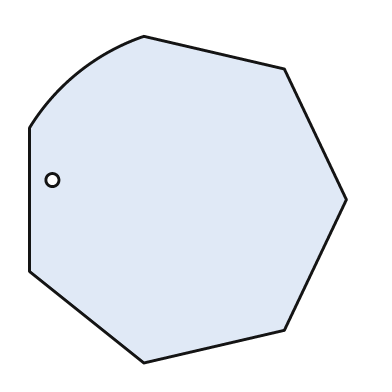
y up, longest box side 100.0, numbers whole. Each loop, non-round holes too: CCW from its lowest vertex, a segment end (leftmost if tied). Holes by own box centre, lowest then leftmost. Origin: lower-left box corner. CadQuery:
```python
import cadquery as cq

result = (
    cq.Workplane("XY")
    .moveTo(35.0, 0.0)
    .lineTo(78.0, 10.0)
    .lineTo(97.0, 50.0)
    .lineTo(78.0, 90.0)
    .lineTo(35.0, 100.0)
    .threePointArc((15.0, 89.0), (0.0, 72.0))
    .lineTo(0.0, 28.0)
    .close()
    .moveTo(7.0, 56.0)
    .circle(2.0)
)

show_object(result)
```